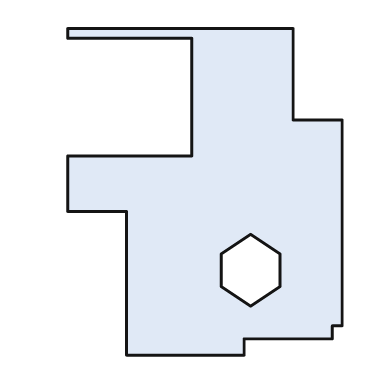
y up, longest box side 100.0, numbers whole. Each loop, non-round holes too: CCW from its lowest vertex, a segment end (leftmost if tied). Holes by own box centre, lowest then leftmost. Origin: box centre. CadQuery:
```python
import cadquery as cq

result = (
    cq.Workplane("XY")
    .moveTo(-24.0, -50.0)
    .lineTo(12.0, -50.0)
    .lineTo(12.0, -45.0)
    .lineTo(39.0, -45.0)
    .lineTo(39.0, -41.0)
    .lineTo(42.0, -41.0)
    .lineTo(42.0, 22.0)
    .lineTo(27.0, 22.0)
    .lineTo(27.0, 50.0)
    .lineTo(-42.0, 50.0)
    .lineTo(-42.0, 47.0)
    .lineTo(-4.0, 47.0)
    .lineTo(-4.0, 11.0)
    .lineTo(-42.0, 11.0)
    .lineTo(-42.0, -6.0)
    .lineTo(-24.0, -6.0)
    .close()
    .moveTo(14.0, -35.0)
    .lineTo(23.0, -29.0)
    .lineTo(23.0, -19.0)
    .lineTo(14.0, -13.0)
    .lineTo(5.0, -19.0)
    .lineTo(5.0, -29.0)
    .close()
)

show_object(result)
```